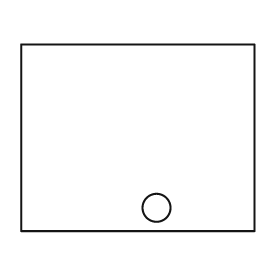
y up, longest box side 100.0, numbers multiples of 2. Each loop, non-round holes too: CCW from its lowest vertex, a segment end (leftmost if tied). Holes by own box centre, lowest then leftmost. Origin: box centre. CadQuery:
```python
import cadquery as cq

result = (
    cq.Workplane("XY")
    .moveTo(-50.0, -40.0)
    .lineTo(50.0, -40.0)
    .lineTo(50.0, 40.0)
    .lineTo(-50.0, 40.0)
    .close()
    .moveTo(8.0, -30.0)
    .circle(6.0)
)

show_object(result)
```